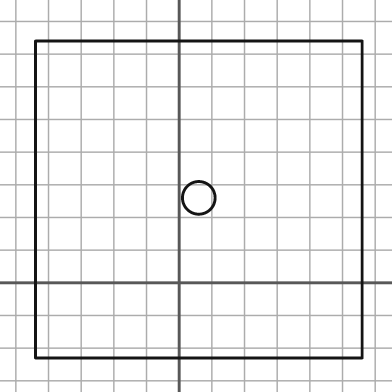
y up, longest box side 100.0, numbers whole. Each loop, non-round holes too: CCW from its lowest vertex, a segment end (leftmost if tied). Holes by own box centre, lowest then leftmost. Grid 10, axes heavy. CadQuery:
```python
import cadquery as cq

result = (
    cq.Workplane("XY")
    .moveTo(-44.0, -23.0)
    .lineTo(56.0, -23.0)
    .lineTo(56.0, 74.0)
    .lineTo(-44.0, 74.0)
    .close()
    .moveTo(6.0, 26.0)
    .circle(5.0)
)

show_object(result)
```